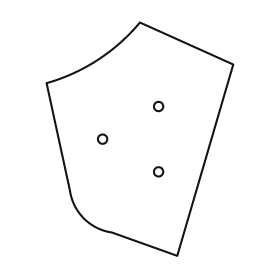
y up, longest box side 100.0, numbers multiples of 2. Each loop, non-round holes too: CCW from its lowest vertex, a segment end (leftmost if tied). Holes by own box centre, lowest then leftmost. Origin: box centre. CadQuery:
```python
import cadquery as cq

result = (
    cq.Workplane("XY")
    .moveTo(16.0, -50.0)
    .lineTo(40.0, 32.0)
    .lineTo(0.0, 50.0)
    .threePointArc((-18.0, 34.0), (-40.0, 24.0))
    .lineTo(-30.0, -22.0)
    .threePointArc((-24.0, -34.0), (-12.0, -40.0))
    .close()
    .moveTo(8.0, -14.0)
    .circle(2.0)
    .moveTo(-16.0, 0.0)
    .circle(2.0)
    .moveTo(8.0, 14.0)
    .circle(2.0)
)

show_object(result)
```